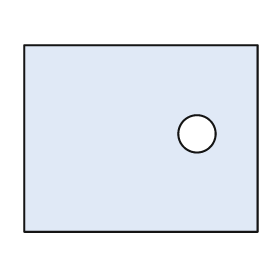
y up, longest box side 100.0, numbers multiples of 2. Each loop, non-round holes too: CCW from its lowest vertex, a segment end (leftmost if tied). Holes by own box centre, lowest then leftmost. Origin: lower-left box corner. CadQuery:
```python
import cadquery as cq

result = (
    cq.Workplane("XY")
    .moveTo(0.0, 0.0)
    .lineTo(100.0, 0.0)
    .lineTo(100.0, 80.0)
    .lineTo(0.0, 80.0)
    .close()
    .moveTo(74.0, 42.0)
    .circle(8.0)
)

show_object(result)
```